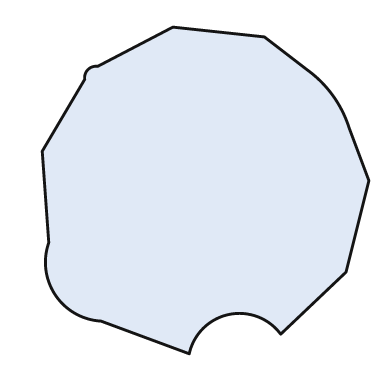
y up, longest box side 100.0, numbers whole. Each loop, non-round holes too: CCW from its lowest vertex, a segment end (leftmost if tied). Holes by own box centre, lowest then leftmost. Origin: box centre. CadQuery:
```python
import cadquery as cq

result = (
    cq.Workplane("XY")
    .moveTo(-5.0, -50.0)
    .threePointArc((7.0, -38.0), (23.0, -44.0))
    .lineTo(43.0, -25.0)
    .lineTo(50.0, 3.0)
    .lineTo(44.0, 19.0)
    .threePointArc((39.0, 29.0), (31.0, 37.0))
    .lineTo(18.0, 47.0)
    .lineTo(-10.0, 50.0)
    .lineTo(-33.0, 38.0)
    .threePointArc((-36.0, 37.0), (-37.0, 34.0))
    .lineTo(-50.0, 12.0)
    .lineTo(-48.0, -16.0)
    .threePointArc((-46.0, -32.0), (-32.0, -40.0))
    .close()
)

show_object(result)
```